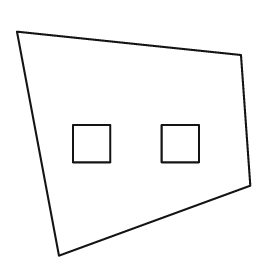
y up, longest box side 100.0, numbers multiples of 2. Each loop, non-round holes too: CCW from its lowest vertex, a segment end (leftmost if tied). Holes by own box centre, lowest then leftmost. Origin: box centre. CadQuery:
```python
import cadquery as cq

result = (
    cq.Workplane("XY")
    .moveTo(-32.0, -48.0)
    .lineTo(50.0, -18.0)
    .lineTo(46.0, 38.0)
    .lineTo(-50.0, 48.0)
    .close()
    .moveTo(-26.0, -8.0)
    .lineTo(-10.0, -8.0)
    .lineTo(-10.0, 8.0)
    .lineTo(-26.0, 8.0)
    .close()
    .moveTo(12.0, -8.0)
    .lineTo(28.0, -8.0)
    .lineTo(28.0, 8.0)
    .lineTo(12.0, 8.0)
    .close()
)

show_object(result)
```